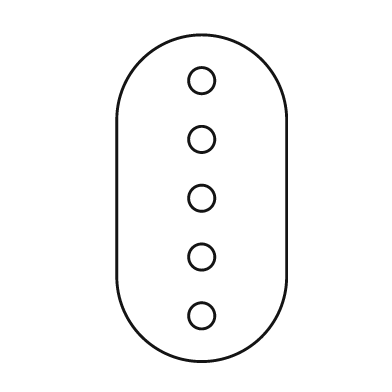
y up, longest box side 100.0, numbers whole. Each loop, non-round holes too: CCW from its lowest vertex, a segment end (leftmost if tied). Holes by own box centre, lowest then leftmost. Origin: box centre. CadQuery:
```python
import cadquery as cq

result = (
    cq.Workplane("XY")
    .moveTo(-26.0, -24.0)
    .threePointArc((0.0, -50.0), (26.0, -24.0))
    .lineTo(26.0, 24.0)
    .threePointArc((0.0, 50.0), (-26.0, 24.0))
    .close()
    .moveTo(0.0, -36.0)
    .circle(4.0)
    .moveTo(0.0, -18.0)
    .circle(4.0)
    .moveTo(0.0, 0.0)
    .circle(4.0)
    .moveTo(0.0, 18.0)
    .circle(4.0)
    .moveTo(0.0, 36.0)
    .circle(4.0)
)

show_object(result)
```